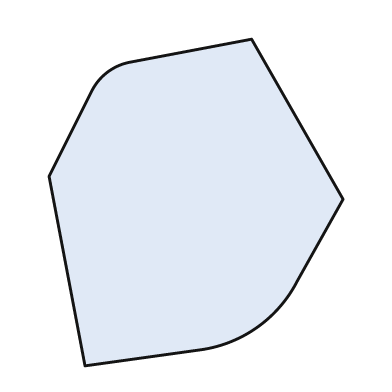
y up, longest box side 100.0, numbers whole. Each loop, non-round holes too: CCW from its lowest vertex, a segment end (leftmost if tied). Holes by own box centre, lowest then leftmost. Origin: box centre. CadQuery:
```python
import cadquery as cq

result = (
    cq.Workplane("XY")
    .moveTo(-34.0, -50.0)
    .lineTo(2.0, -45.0)
    .threePointArc((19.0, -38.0), (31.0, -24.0))
    .lineTo(45.0, 1.0)
    .lineTo(17.0, 50.0)
    .lineTo(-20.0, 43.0)
    .threePointArc((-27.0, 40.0), (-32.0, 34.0))
    .lineTo(-45.0, 8.0)
    .close()
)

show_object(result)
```